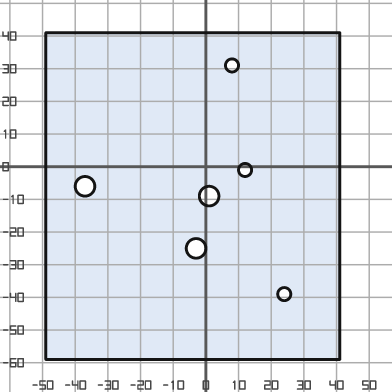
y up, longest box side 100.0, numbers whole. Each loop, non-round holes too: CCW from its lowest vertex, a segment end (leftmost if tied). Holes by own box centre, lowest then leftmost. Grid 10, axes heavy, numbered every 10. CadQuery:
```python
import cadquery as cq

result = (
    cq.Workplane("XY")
    .moveTo(-49.0, -59.0)
    .lineTo(41.0, -59.0)
    .lineTo(41.0, 41.0)
    .lineTo(-49.0, 41.0)
    .close()
    .moveTo(24.0, -39.0)
    .circle(2.0)
    .moveTo(-3.0, -25.0)
    .circle(3.0)
    .moveTo(1.0, -9.0)
    .circle(3.0)
    .moveTo(-37.0, -6.0)
    .circle(3.0)
    .moveTo(12.0, -1.0)
    .circle(2.0)
    .moveTo(8.0, 31.0)
    .circle(2.0)
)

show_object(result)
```